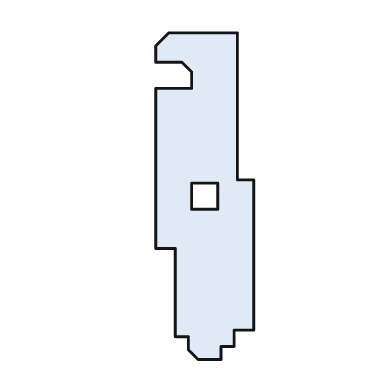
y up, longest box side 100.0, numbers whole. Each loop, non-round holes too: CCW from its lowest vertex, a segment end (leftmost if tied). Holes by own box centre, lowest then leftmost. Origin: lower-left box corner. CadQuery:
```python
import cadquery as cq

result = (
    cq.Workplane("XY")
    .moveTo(13.0, 0.0)
    .lineTo(20.0, 0.0)
    .lineTo(20.0, 4.0)
    .lineTo(24.0, 4.0)
    .lineTo(24.0, 9.0)
    .lineTo(30.0, 9.0)
    .lineTo(30.0, 55.0)
    .lineTo(25.0, 55.0)
    .lineTo(25.0, 100.0)
    .lineTo(4.0, 100.0)
    .lineTo(0.0, 96.0)
    .lineTo(0.0, 91.0)
    .lineTo(8.0, 91.0)
    .lineTo(11.0, 88.0)
    .lineTo(11.0, 83.0)
    .lineTo(0.0, 83.0)
    .lineTo(0.0, 34.0)
    .lineTo(6.0, 34.0)
    .lineTo(6.0, 7.0)
    .lineTo(10.0, 7.0)
    .lineTo(10.0, 3.0)
    .close()
    .moveTo(11.0, 46.0)
    .lineTo(19.0, 46.0)
    .lineTo(19.0, 54.0)
    .lineTo(11.0, 54.0)
    .close()
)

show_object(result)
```